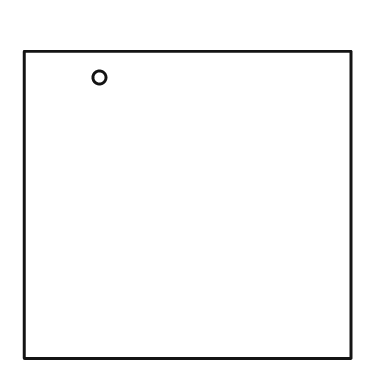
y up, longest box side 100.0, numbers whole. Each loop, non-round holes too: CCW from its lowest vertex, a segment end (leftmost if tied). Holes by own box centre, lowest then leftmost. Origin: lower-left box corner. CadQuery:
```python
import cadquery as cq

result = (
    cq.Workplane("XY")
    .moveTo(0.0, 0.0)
    .lineTo(100.0, 0.0)
    .lineTo(100.0, 94.0)
    .lineTo(0.0, 94.0)
    .close()
    .moveTo(23.0, 86.0)
    .circle(2.0)
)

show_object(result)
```